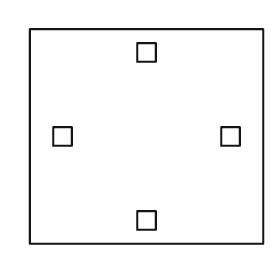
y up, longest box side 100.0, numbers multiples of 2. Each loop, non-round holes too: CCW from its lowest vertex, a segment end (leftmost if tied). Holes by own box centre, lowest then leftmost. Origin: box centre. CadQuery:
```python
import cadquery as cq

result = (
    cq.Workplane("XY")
    .moveTo(-50.0, -46.0)
    .lineTo(50.0, -46.0)
    .lineTo(50.0, 46.0)
    .lineTo(-50.0, 46.0)
    .close()
    .moveTo(-4.0, -40.0)
    .lineTo(4.0, -40.0)
    .lineTo(4.0, -32.0)
    .lineTo(-4.0, -32.0)
    .close()
    .moveTo(-40.0, -4.0)
    .lineTo(-32.0, -4.0)
    .lineTo(-32.0, 4.0)
    .lineTo(-40.0, 4.0)
    .close()
    .moveTo(32.0, -4.0)
    .lineTo(40.0, -4.0)
    .lineTo(40.0, 4.0)
    .lineTo(32.0, 4.0)
    .close()
    .moveTo(-4.0, 32.0)
    .lineTo(4.0, 32.0)
    .lineTo(4.0, 40.0)
    .lineTo(-4.0, 40.0)
    .close()
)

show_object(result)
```